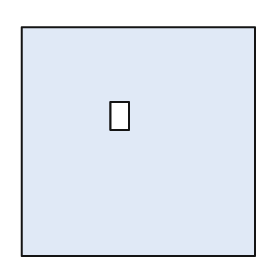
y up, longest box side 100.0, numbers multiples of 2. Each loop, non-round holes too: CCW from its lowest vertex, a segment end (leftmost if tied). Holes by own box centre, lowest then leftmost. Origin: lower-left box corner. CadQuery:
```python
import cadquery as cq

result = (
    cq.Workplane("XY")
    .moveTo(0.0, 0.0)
    .lineTo(100.0, 0.0)
    .lineTo(100.0, 98.0)
    .lineTo(0.0, 98.0)
    .close()
    .moveTo(38.0, 54.0)
    .lineTo(46.0, 54.0)
    .lineTo(46.0, 66.0)
    .lineTo(38.0, 66.0)
    .close()
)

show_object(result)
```